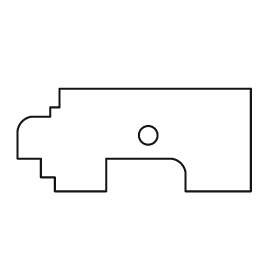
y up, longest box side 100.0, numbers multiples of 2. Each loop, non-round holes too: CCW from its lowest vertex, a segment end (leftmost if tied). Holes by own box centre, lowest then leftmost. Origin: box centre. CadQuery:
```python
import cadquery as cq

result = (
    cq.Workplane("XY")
    .moveTo(-34.0, -22.0)
    .lineTo(-12.0, -22.0)
    .lineTo(-12.0, -8.0)
    .lineTo(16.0, -8.0)
    .threePointArc((20.0, -10.0), (22.0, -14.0))
    .lineTo(22.0, -22.0)
    .lineTo(50.0, -22.0)
    .lineTo(50.0, 22.0)
    .lineTo(-32.0, 22.0)
    .lineTo(-32.0, 14.0)
    .lineTo(-36.0, 14.0)
    .lineTo(-36.0, 10.0)
    .lineTo(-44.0, 10.0)
    .threePointArc((-48.0, 8.0), (-50.0, 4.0))
    .lineTo(-50.0, -8.0)
    .lineTo(-40.0, -8.0)
    .lineTo(-40.0, -16.0)
    .lineTo(-34.0, -16.0)
    .close()
    .moveTo(6.0, 2.0)
    .circle(4.0)
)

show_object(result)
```